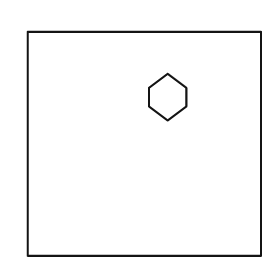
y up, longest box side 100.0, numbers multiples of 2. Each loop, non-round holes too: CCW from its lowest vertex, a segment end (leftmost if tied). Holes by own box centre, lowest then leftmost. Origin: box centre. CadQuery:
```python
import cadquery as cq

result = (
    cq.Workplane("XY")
    .moveTo(-50.0, -48.0)
    .lineTo(50.0, -48.0)
    .lineTo(50.0, 48.0)
    .lineTo(-50.0, 48.0)
    .close()
    .moveTo(10.0, 10.0)
    .lineTo(18.0, 16.0)
    .lineTo(18.0, 24.0)
    .lineTo(10.0, 30.0)
    .lineTo(2.0, 24.0)
    .lineTo(2.0, 16.0)
    .close()
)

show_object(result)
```